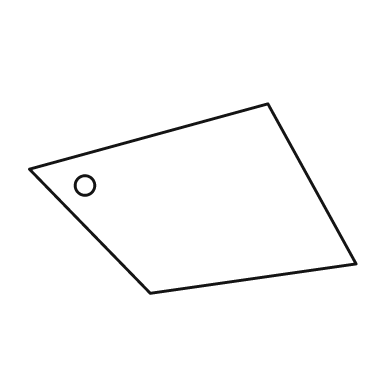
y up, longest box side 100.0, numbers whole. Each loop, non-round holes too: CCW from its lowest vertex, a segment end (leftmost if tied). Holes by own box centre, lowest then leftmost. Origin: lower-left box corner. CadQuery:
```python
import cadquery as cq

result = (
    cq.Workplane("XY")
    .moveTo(37.0, 0.0)
    .lineTo(100.0, 9.0)
    .lineTo(73.0, 58.0)
    .lineTo(0.0, 38.0)
    .close()
    .moveTo(17.0, 33.0)
    .circle(3.0)
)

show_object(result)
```